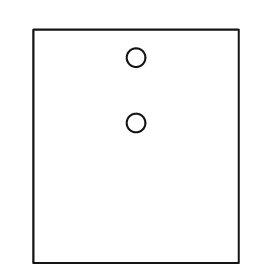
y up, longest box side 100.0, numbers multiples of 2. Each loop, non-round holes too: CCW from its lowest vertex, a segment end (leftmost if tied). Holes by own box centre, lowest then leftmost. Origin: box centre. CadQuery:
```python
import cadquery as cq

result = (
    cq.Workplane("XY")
    .moveTo(-44.0, -50.0)
    .lineTo(44.0, -50.0)
    .lineTo(44.0, 50.0)
    .lineTo(-44.0, 50.0)
    .close()
    .moveTo(0.0, 10.0)
    .circle(4.0)
    .moveTo(0.0, 38.0)
    .circle(4.0)
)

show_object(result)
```